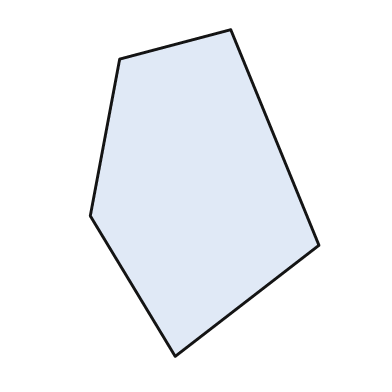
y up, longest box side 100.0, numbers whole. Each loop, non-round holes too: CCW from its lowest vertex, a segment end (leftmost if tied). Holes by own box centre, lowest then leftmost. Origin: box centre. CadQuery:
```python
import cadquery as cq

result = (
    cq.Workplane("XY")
    .moveTo(-9.0, -50.0)
    .lineTo(35.0, -16.0)
    .lineTo(8.0, 50.0)
    .lineTo(-26.0, 41.0)
    .lineTo(-35.0, -7.0)
    .close()
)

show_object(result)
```